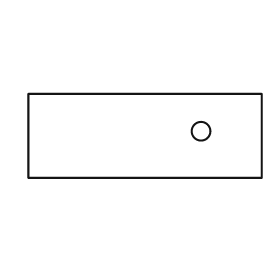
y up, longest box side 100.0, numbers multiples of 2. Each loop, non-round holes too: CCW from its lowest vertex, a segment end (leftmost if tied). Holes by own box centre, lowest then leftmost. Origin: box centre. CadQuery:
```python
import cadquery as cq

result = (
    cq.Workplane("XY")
    .moveTo(-50.0, -18.0)
    .lineTo(50.0, -18.0)
    .lineTo(50.0, 18.0)
    .lineTo(-50.0, 18.0)
    .close()
    .moveTo(24.0, 2.0)
    .circle(4.0)
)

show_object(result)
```